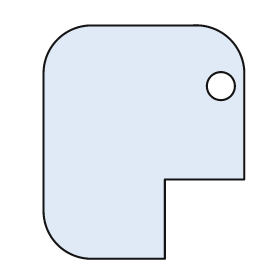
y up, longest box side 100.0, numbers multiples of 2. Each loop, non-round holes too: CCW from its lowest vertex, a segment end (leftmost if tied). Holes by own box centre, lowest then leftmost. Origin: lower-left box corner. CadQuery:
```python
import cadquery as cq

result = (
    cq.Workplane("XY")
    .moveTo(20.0, 0.0)
    .lineTo(52.0, 0.0)
    .lineTo(52.0, 34.0)
    .lineTo(86.0, 34.0)
    .lineTo(86.0, 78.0)
    .threePointArc((80.0, 94.0), (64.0, 100.0))
    .lineTo(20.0, 100.0)
    .threePointArc((6.0, 94.0), (0.0, 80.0))
    .lineTo(0.0, 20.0)
    .threePointArc((6.0, 6.0), (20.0, 0.0))
    .close()
    .moveTo(76.0, 74.0)
    .circle(6.0)
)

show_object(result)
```